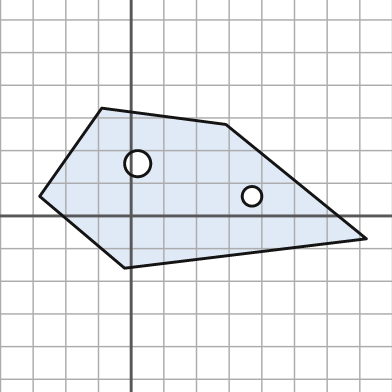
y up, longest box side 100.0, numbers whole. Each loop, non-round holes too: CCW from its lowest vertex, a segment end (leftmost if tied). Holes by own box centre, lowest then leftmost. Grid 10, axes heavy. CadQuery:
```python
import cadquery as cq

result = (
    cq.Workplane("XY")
    .moveTo(-2.0, -16.0)
    .lineTo(72.0, -7.0)
    .lineTo(29.0, 28.0)
    .lineTo(-9.0, 33.0)
    .lineTo(-28.0, 6.0)
    .close()
    .moveTo(37.0, 6.0)
    .circle(3.0)
    .moveTo(2.0, 16.0)
    .circle(4.0)
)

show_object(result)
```